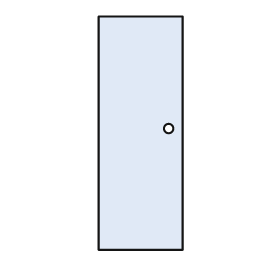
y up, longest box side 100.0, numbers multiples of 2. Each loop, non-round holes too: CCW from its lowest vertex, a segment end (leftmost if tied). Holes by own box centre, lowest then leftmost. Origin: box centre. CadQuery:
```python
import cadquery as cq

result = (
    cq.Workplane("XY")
    .moveTo(-18.0, -50.0)
    .lineTo(18.0, -50.0)
    .lineTo(18.0, 50.0)
    .lineTo(-18.0, 50.0)
    .close()
    .moveTo(12.0, 2.0)
    .circle(2.0)
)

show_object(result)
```